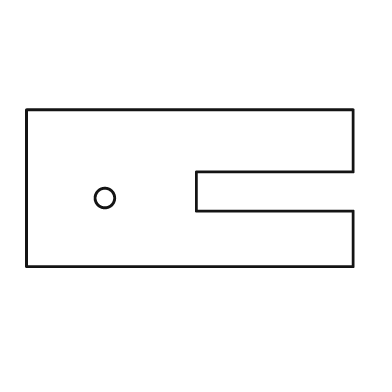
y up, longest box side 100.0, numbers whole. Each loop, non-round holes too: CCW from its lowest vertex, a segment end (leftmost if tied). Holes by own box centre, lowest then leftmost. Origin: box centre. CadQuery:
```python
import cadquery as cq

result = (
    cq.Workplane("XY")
    .moveTo(-50.0, -24.0)
    .lineTo(50.0, -24.0)
    .lineTo(50.0, -7.0)
    .lineTo(2.0, -7.0)
    .lineTo(2.0, 5.0)
    .lineTo(50.0, 5.0)
    .lineTo(50.0, 24.0)
    .lineTo(-50.0, 24.0)
    .close()
    .moveTo(-26.0, -3.0)
    .circle(3.0)
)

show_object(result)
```